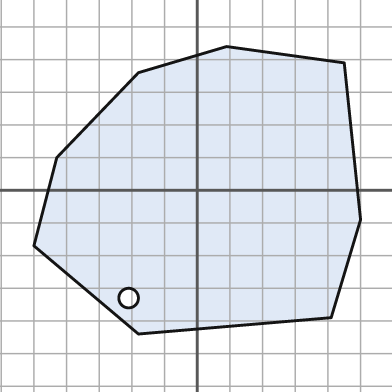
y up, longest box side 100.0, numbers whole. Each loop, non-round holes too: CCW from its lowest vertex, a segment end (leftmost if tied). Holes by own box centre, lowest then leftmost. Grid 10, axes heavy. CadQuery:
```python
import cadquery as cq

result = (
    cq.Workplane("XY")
    .moveTo(-18.0, -44.0)
    .lineTo(41.0, -39.0)
    .lineTo(50.0, -9.0)
    .lineTo(45.0, 39.0)
    .lineTo(9.0, 44.0)
    .lineTo(-18.0, 36.0)
    .lineTo(-43.0, 10.0)
    .lineTo(-50.0, -17.0)
    .close()
    .moveTo(-21.0, -33.0)
    .circle(3.0)
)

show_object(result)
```